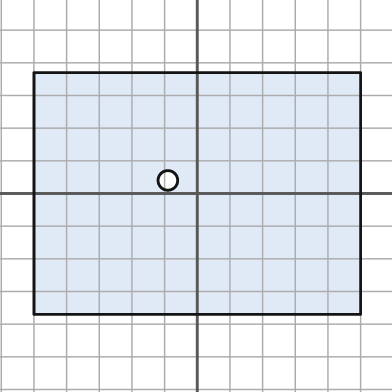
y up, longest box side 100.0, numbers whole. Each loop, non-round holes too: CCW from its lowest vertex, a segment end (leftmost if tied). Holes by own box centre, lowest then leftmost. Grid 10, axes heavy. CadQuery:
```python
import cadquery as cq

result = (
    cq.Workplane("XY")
    .moveTo(-50.0, -37.0)
    .lineTo(50.0, -37.0)
    .lineTo(50.0, 37.0)
    .lineTo(-50.0, 37.0)
    .close()
    .moveTo(-9.0, 4.0)
    .circle(3.0)
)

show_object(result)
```